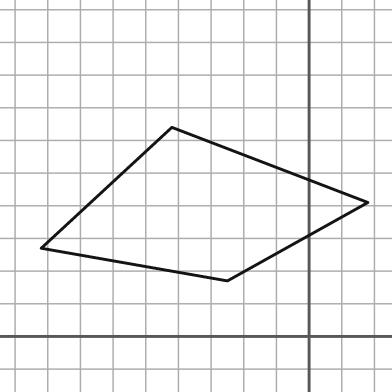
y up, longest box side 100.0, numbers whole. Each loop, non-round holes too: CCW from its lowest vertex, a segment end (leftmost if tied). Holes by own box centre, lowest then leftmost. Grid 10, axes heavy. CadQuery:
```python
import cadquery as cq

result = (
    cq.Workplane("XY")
    .moveTo(-25.0, 17.0)
    .lineTo(18.0, 41.0)
    .lineTo(-42.0, 64.0)
    .lineTo(-82.0, 27.0)
    .close()
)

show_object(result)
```